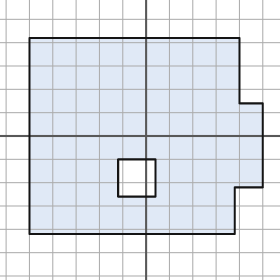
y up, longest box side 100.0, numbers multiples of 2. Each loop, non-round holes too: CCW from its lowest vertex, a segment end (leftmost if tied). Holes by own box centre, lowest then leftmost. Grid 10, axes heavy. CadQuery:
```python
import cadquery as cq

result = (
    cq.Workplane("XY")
    .moveTo(-50.0, -42.0)
    .lineTo(38.0, -42.0)
    .lineTo(38.0, -22.0)
    .lineTo(50.0, -22.0)
    .lineTo(50.0, 14.0)
    .lineTo(40.0, 14.0)
    .lineTo(40.0, 42.0)
    .lineTo(-50.0, 42.0)
    .close()
    .moveTo(-12.0, -26.0)
    .lineTo(4.0, -26.0)
    .lineTo(4.0, -10.0)
    .lineTo(-12.0, -10.0)
    .close()
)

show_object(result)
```